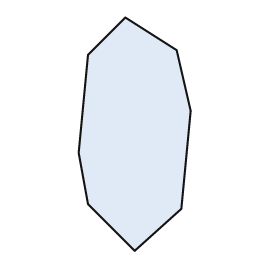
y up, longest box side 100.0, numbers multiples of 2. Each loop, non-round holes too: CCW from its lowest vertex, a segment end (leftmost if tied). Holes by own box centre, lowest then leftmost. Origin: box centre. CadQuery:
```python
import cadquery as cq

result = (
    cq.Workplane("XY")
    .moveTo(0.0, -50.0)
    .lineTo(20.0, -32.0)
    .lineTo(24.0, 10.0)
    .lineTo(18.0, 36.0)
    .lineTo(-4.0, 50.0)
    .lineTo(-20.0, 34.0)
    .lineTo(-24.0, -8.0)
    .lineTo(-20.0, -30.0)
    .close()
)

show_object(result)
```